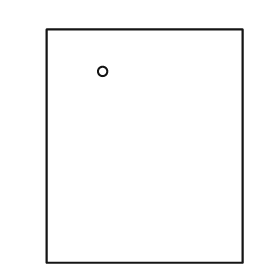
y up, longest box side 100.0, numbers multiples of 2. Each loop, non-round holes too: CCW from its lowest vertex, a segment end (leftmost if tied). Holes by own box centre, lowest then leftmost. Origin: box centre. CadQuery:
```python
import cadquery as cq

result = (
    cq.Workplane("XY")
    .moveTo(-42.0, -50.0)
    .lineTo(42.0, -50.0)
    .lineTo(42.0, 50.0)
    .lineTo(-42.0, 50.0)
    .close()
    .moveTo(-18.0, 32.0)
    .circle(2.0)
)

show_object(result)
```